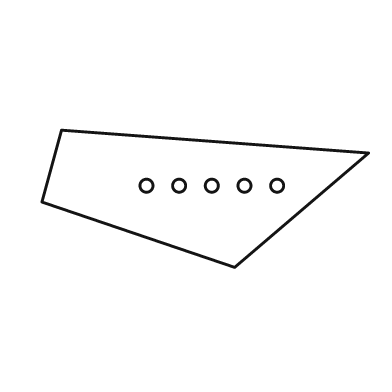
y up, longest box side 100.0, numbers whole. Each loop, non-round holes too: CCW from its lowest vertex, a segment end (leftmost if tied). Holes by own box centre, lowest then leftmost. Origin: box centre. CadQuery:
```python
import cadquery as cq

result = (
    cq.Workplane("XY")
    .moveTo(9.0, -21.0)
    .lineTo(50.0, 14.0)
    .lineTo(-44.0, 21.0)
    .lineTo(-50.0, -1.0)
    .close()
    .moveTo(-18.0, 4.0)
    .circle(2.0)
    .moveTo(-8.0, 4.0)
    .circle(2.0)
    .moveTo(2.0, 4.0)
    .circle(2.0)
    .moveTo(12.0, 4.0)
    .circle(2.0)
    .moveTo(22.0, 4.0)
    .circle(2.0)
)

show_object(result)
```